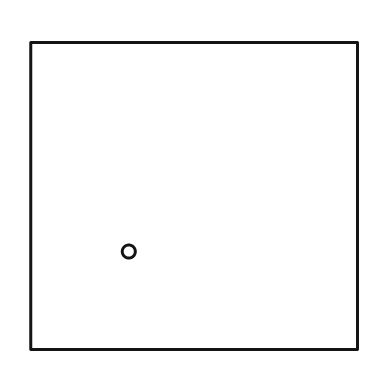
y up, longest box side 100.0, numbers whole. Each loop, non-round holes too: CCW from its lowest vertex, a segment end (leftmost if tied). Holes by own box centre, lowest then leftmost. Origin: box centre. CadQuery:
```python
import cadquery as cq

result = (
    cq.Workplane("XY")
    .moveTo(-50.0, -47.0)
    .lineTo(50.0, -47.0)
    .lineTo(50.0, 47.0)
    .lineTo(-50.0, 47.0)
    .close()
    .moveTo(-20.0, -17.0)
    .circle(2.0)
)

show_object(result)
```